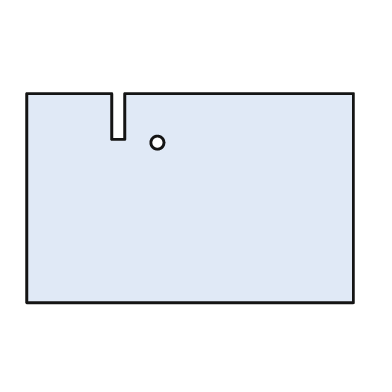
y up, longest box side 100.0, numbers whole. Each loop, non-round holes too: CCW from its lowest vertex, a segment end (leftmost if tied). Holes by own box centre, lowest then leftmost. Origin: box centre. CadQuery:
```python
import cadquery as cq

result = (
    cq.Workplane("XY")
    .moveTo(-50.0, -32.0)
    .lineTo(50.0, -32.0)
    .lineTo(50.0, 32.0)
    .lineTo(-20.0, 32.0)
    .lineTo(-20.0, 18.0)
    .lineTo(-24.0, 18.0)
    .lineTo(-24.0, 32.0)
    .lineTo(-50.0, 32.0)
    .close()
    .moveTo(-10.0, 17.0)
    .circle(2.0)
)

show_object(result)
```